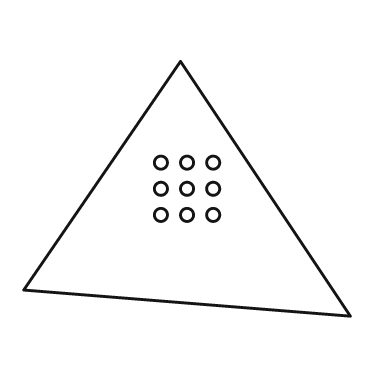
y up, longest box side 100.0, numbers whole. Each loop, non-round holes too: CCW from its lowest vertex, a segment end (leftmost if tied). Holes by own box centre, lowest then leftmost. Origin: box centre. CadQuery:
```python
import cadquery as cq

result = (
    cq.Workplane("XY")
    .moveTo(50.0, -39.0)
    .lineTo(-2.0, 39.0)
    .lineTo(-50.0, -31.0)
    .close()
    .moveTo(-8.0, -8.0)
    .circle(2.0)
    .moveTo(0.0, -8.0)
    .circle(2.0)
    .moveTo(8.0, -8.0)
    .circle(2.0)
    .moveTo(-8.0, 0.0)
    .circle(2.0)
    .moveTo(0.0, 0.0)
    .circle(2.0)
    .moveTo(8.0, 0.0)
    .circle(2.0)
    .moveTo(-8.0, 8.0)
    .circle(2.0)
    .moveTo(0.0, 8.0)
    .circle(2.0)
    .moveTo(8.0, 8.0)
    .circle(2.0)
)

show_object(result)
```